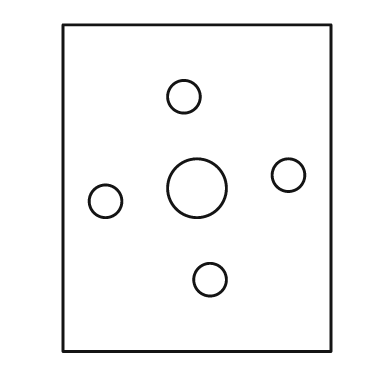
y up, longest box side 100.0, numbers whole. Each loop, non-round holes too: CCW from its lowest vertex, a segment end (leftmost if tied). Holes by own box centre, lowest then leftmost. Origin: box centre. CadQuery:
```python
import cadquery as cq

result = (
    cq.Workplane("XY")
    .moveTo(-41.0, -50.0)
    .lineTo(41.0, -50.0)
    .lineTo(41.0, 50.0)
    .lineTo(-41.0, 50.0)
    .close()
    .moveTo(4.0, -28.0)
    .circle(5.0)
    .moveTo(-28.0, -4.0)
    .circle(5.0)
    .moveTo(0.0, 0.0)
    .circle(9.0)
    .moveTo(28.0, 4.0)
    .circle(5.0)
    .moveTo(-4.0, 28.0)
    .circle(5.0)
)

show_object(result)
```